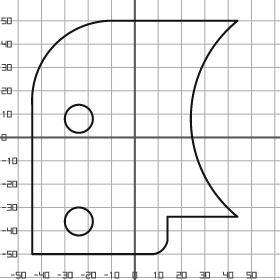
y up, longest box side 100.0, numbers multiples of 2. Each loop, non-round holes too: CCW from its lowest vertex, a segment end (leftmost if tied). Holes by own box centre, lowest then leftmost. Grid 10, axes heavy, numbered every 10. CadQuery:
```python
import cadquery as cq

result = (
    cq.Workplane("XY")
    .moveTo(-44.0, -50.0)
    .lineTo(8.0, -50.0)
    .threePointArc((12.0, -48.0), (14.0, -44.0))
    .lineTo(14.0, -34.0)
    .lineTo(44.0, -34.0)
    .threePointArc((24.0, 8.0), (44.0, 50.0))
    .lineTo(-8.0, 50.0)
    .threePointArc((-34.0, 40.0), (-44.0, 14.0))
    .close()
    .moveTo(-24.0, -36.0)
    .circle(6.0)
    .moveTo(-24.0, 8.0)
    .circle(6.0)
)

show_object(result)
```